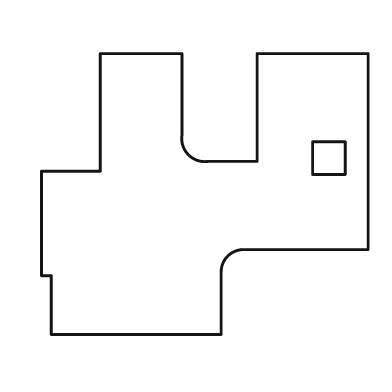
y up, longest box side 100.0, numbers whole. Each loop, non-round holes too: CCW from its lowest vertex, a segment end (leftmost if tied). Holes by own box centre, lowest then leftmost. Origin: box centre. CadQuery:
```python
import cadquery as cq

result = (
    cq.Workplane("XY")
    .moveTo(-47.0, -43.0)
    .lineTo(5.0, -43.0)
    .lineTo(5.0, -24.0)
    .threePointArc((7.0, -19.0), (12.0, -17.0))
    .lineTo(50.0, -17.0)
    .lineTo(50.0, 43.0)
    .lineTo(16.0, 43.0)
    .lineTo(16.0, 10.0)
    .lineTo(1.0, 10.0)
    .threePointArc((-5.0, 12.0), (-7.0, 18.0))
    .lineTo(-7.0, 43.0)
    .lineTo(-32.0, 43.0)
    .lineTo(-32.0, 7.0)
    .lineTo(-50.0, 7.0)
    .lineTo(-50.0, -25.0)
    .lineTo(-47.0, -25.0)
    .close()
    .moveTo(33.0, 6.0)
    .lineTo(43.0, 6.0)
    .lineTo(43.0, 16.0)
    .lineTo(33.0, 16.0)
    .close()
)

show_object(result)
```